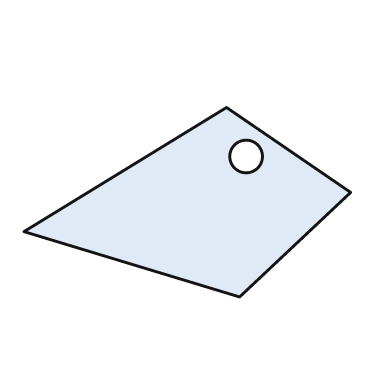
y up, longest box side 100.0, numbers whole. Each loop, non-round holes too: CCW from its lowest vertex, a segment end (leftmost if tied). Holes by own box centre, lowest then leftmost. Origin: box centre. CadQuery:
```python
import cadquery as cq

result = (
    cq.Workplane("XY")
    .moveTo(16.0, -29.0)
    .lineTo(50.0, 3.0)
    .lineTo(12.0, 29.0)
    .lineTo(-50.0, -9.0)
    .close()
    .moveTo(18.0, 14.0)
    .circle(5.0)
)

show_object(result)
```